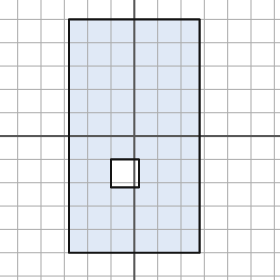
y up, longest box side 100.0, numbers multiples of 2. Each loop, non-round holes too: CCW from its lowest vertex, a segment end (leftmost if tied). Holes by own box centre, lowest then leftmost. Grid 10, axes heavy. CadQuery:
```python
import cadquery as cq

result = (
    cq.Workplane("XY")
    .moveTo(-28.0, -50.0)
    .lineTo(28.0, -50.0)
    .lineTo(28.0, 50.0)
    .lineTo(-28.0, 50.0)
    .close()
    .moveTo(-10.0, -22.0)
    .lineTo(2.0, -22.0)
    .lineTo(2.0, -10.0)
    .lineTo(-10.0, -10.0)
    .close()
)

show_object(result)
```